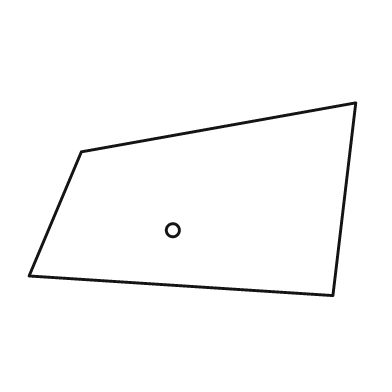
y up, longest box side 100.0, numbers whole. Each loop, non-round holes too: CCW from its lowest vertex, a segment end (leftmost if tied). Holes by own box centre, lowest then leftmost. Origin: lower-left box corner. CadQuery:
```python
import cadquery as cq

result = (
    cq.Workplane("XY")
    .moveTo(93.0, 0.0)
    .lineTo(100.0, 59.0)
    .lineTo(16.0, 44.0)
    .lineTo(0.0, 6.0)
    .close()
    .moveTo(44.0, 20.0)
    .circle(2.0)
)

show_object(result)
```